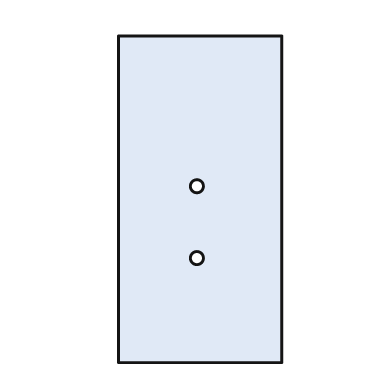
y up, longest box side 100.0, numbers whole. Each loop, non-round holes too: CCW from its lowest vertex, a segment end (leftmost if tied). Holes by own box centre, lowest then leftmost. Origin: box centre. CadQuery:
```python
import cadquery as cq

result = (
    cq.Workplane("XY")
    .moveTo(-25.0, -50.0)
    .lineTo(25.0, -50.0)
    .lineTo(25.0, 50.0)
    .lineTo(-25.0, 50.0)
    .close()
    .moveTo(-1.0, -18.0)
    .circle(2.0)
    .moveTo(-1.0, 4.0)
    .circle(2.0)
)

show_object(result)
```